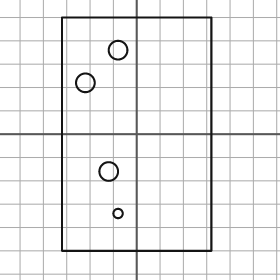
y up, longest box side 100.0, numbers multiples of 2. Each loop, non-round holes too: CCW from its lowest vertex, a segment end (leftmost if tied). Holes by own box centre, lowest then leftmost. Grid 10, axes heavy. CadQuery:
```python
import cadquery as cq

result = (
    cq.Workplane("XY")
    .moveTo(-32.0, -50.0)
    .lineTo(32.0, -50.0)
    .lineTo(32.0, 50.0)
    .lineTo(-32.0, 50.0)
    .close()
    .moveTo(-8.0, -34.0)
    .circle(2.0)
    .moveTo(-12.0, -16.0)
    .circle(4.0)
    .moveTo(-22.0, 22.0)
    .circle(4.0)
    .moveTo(-8.0, 36.0)
    .circle(4.0)
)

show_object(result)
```